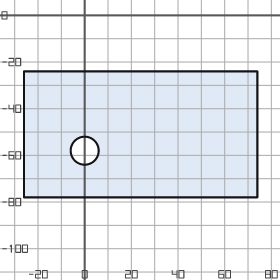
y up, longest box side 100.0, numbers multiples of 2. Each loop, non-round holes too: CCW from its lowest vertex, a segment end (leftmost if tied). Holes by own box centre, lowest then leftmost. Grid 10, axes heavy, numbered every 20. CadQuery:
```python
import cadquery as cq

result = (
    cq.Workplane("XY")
    .moveTo(-26.0, -78.0)
    .lineTo(74.0, -78.0)
    .lineTo(74.0, -24.0)
    .lineTo(-26.0, -24.0)
    .close()
    .moveTo(0.0, -58.0)
    .circle(6.0)
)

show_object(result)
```